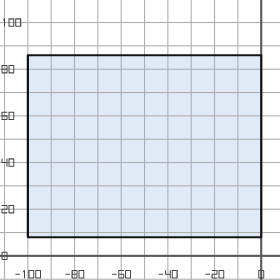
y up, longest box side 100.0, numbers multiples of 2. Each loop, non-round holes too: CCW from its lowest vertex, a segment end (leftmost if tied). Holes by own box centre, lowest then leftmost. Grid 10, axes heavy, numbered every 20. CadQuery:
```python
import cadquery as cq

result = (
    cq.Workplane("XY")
    .moveTo(-100.0, 8.0)
    .lineTo(0.0, 8.0)
    .lineTo(0.0, 86.0)
    .lineTo(-100.0, 86.0)
    .close()
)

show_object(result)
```